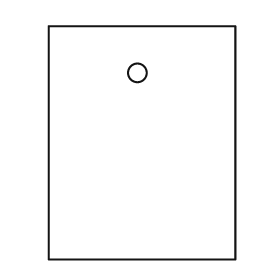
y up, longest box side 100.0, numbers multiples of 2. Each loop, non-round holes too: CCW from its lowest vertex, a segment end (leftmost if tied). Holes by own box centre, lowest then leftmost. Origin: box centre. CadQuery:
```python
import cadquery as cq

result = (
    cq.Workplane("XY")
    .moveTo(-40.0, -50.0)
    .lineTo(40.0, -50.0)
    .lineTo(40.0, 50.0)
    .lineTo(-40.0, 50.0)
    .close()
    .moveTo(-2.0, 30.0)
    .circle(4.0)
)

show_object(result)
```